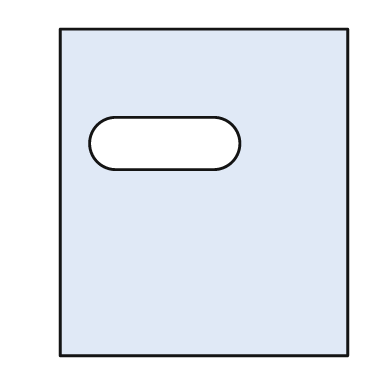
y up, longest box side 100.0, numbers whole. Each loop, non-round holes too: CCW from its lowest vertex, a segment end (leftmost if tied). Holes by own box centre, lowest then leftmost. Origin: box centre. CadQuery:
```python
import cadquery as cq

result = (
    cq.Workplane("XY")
    .moveTo(-44.0, -50.0)
    .lineTo(44.0, -50.0)
    .lineTo(44.0, 50.0)
    .lineTo(-44.0, 50.0)
    .close()
    .moveTo(-27.0, 7.0)
    .lineTo(3.0, 7.0)
    .threePointArc((11.0, 15.0), (3.0, 23.0))
    .lineTo(-27.0, 23.0)
    .threePointArc((-35.0, 15.0), (-27.0, 7.0))
    .close()
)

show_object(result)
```